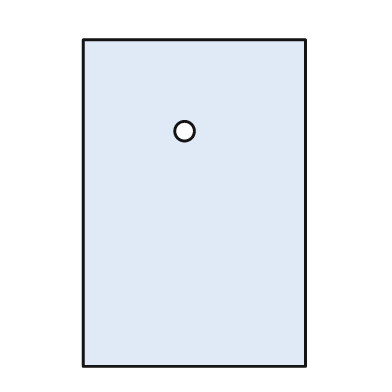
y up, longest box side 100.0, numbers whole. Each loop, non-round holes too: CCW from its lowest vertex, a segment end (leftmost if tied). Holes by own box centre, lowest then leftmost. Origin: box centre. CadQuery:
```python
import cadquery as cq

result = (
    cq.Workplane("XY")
    .moveTo(-34.0, -50.0)
    .lineTo(34.0, -50.0)
    .lineTo(34.0, 50.0)
    .lineTo(-34.0, 50.0)
    .close()
    .moveTo(-3.0, 22.0)
    .circle(3.0)
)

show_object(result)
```